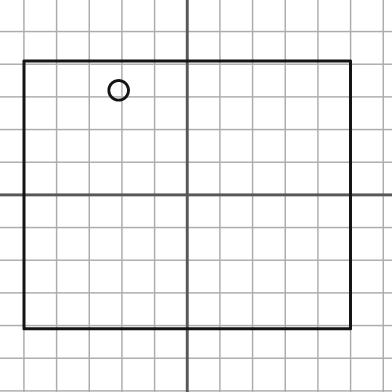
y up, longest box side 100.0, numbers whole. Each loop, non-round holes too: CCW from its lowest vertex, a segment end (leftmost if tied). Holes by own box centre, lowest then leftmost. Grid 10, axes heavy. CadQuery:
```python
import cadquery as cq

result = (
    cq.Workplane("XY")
    .moveTo(-50.0, -41.0)
    .lineTo(50.0, -41.0)
    .lineTo(50.0, 41.0)
    .lineTo(-50.0, 41.0)
    .close()
    .moveTo(-21.0, 32.0)
    .circle(3.0)
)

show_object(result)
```